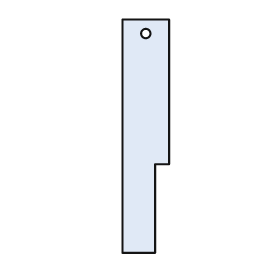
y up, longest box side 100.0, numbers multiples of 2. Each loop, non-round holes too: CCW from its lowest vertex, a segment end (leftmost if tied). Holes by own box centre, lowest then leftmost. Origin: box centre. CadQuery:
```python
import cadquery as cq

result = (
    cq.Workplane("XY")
    .moveTo(-10.0, -50.0)
    .lineTo(4.0, -50.0)
    .lineTo(4.0, -12.0)
    .lineTo(10.0, -12.0)
    .lineTo(10.0, 50.0)
    .lineTo(-10.0, 50.0)
    .close()
    .moveTo(0.0, 44.0)
    .circle(2.0)
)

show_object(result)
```